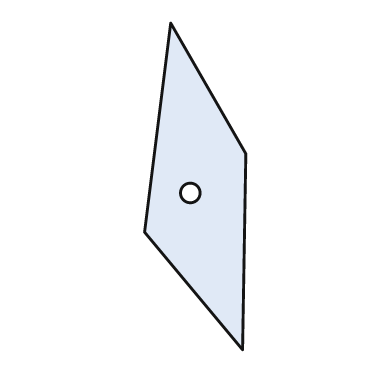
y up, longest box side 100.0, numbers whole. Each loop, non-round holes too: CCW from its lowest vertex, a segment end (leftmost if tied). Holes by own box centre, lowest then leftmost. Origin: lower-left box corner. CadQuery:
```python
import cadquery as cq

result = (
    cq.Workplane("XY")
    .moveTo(30.0, 0.0)
    .lineTo(31.0, 60.0)
    .lineTo(8.0, 100.0)
    .lineTo(0.0, 36.0)
    .close()
    .moveTo(14.0, 48.0)
    .circle(3.0)
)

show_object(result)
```